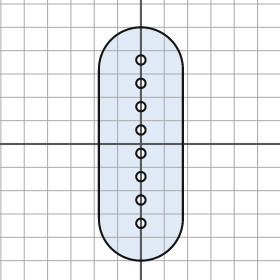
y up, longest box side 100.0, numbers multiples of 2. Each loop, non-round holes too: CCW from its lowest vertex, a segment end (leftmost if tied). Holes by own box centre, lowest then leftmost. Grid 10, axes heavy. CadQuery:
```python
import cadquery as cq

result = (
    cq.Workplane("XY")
    .moveTo(-18.0, -32.0)
    .threePointArc((0.0, -50.0), (18.0, -32.0))
    .lineTo(18.0, 32.0)
    .threePointArc((0.0, 50.0), (-18.0, 32.0))
    .close()
    .moveTo(0.0, -34.0)
    .circle(2.0)
    .moveTo(0.0, -24.0)
    .circle(2.0)
    .moveTo(0.0, -14.0)
    .circle(2.0)
    .moveTo(0.0, -4.0)
    .circle(2.0)
    .moveTo(0.0, 6.0)
    .circle(2.0)
    .moveTo(0.0, 16.0)
    .circle(2.0)
    .moveTo(0.0, 26.0)
    .circle(2.0)
    .moveTo(0.0, 36.0)
    .circle(2.0)
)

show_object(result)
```